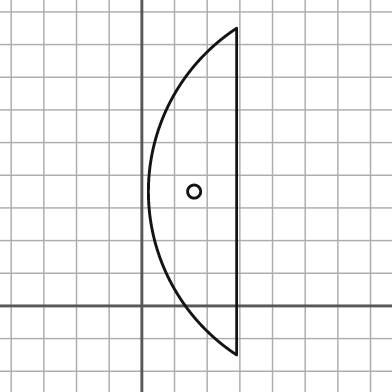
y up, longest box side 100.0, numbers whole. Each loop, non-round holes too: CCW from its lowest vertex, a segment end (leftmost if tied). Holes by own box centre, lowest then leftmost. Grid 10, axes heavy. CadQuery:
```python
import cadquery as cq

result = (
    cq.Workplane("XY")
    .moveTo(29.0, -15.0)
    .lineTo(29.0, 85.0)
    .threePointArc((2.0, 35.0), (29.0, -15.0))
    .close()
    .moveTo(16.0, 35.0)
    .circle(2.0)
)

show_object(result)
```